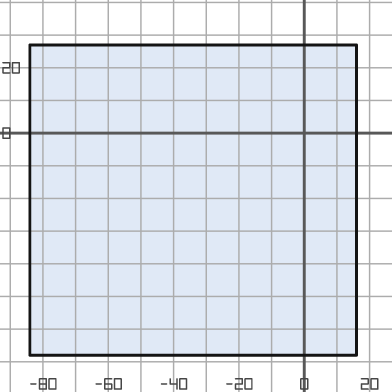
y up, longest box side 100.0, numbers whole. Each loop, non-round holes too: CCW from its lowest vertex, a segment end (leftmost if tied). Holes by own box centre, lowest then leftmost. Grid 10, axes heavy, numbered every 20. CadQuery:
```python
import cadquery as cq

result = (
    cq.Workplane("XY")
    .moveTo(-84.0, -68.0)
    .lineTo(16.0, -68.0)
    .lineTo(16.0, 27.0)
    .lineTo(-84.0, 27.0)
    .close()
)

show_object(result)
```